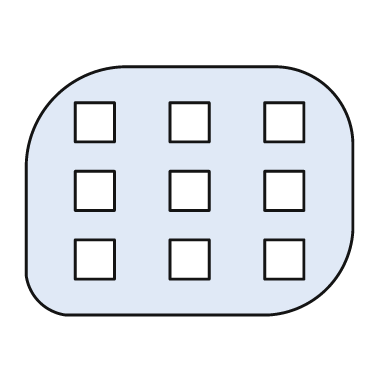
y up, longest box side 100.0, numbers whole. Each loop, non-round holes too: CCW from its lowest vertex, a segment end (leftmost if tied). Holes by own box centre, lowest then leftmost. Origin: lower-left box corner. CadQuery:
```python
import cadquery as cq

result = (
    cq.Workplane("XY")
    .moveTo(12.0, 0.0)
    .lineTo(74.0, 0.0)
    .threePointArc((92.0, 8.0), (100.0, 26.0))
    .lineTo(100.0, 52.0)
    .threePointArc((93.0, 69.0), (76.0, 76.0))
    .lineTo(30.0, 76.0)
    .threePointArc((9.0, 67.0), (0.0, 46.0))
    .lineTo(0.0, 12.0)
    .threePointArc((4.0, 4.0), (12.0, 0.0))
    .close()
    .moveTo(15.0, 11.0)
    .lineTo(27.0, 11.0)
    .lineTo(27.0, 23.0)
    .lineTo(15.0, 23.0)
    .close()
    .moveTo(44.0, 11.0)
    .lineTo(56.0, 11.0)
    .lineTo(56.0, 23.0)
    .lineTo(44.0, 23.0)
    .close()
    .moveTo(73.0, 11.0)
    .lineTo(85.0, 11.0)
    .lineTo(85.0, 23.0)
    .lineTo(73.0, 23.0)
    .close()
    .moveTo(15.0, 32.0)
    .lineTo(27.0, 32.0)
    .lineTo(27.0, 44.0)
    .lineTo(15.0, 44.0)
    .close()
    .moveTo(44.0, 32.0)
    .lineTo(56.0, 32.0)
    .lineTo(56.0, 44.0)
    .lineTo(44.0, 44.0)
    .close()
    .moveTo(73.0, 32.0)
    .lineTo(85.0, 32.0)
    .lineTo(85.0, 44.0)
    .lineTo(73.0, 44.0)
    .close()
    .moveTo(15.0, 53.0)
    .lineTo(27.0, 53.0)
    .lineTo(27.0, 65.0)
    .lineTo(15.0, 65.0)
    .close()
    .moveTo(44.0, 53.0)
    .lineTo(56.0, 53.0)
    .lineTo(56.0, 65.0)
    .lineTo(44.0, 65.0)
    .close()
    .moveTo(73.0, 53.0)
    .lineTo(85.0, 53.0)
    .lineTo(85.0, 65.0)
    .lineTo(73.0, 65.0)
    .close()
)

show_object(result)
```